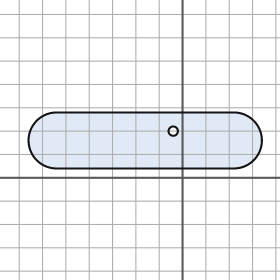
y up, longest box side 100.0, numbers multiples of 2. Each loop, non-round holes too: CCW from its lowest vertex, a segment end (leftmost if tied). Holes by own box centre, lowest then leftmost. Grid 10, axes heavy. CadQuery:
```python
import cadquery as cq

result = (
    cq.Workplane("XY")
    .moveTo(-54.0, 4.0)
    .lineTo(22.0, 4.0)
    .threePointArc((34.0, 16.0), (22.0, 28.0))
    .lineTo(-54.0, 28.0)
    .threePointArc((-66.0, 16.0), (-54.0, 4.0))
    .close()
    .moveTo(-4.0, 20.0)
    .circle(2.0)
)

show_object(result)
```